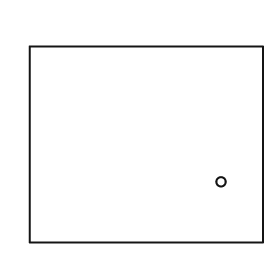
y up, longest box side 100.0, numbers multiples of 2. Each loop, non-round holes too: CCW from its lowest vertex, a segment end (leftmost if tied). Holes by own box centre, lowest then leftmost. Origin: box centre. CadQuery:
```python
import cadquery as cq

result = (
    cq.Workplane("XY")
    .moveTo(-50.0, -42.0)
    .lineTo(50.0, -42.0)
    .lineTo(50.0, 42.0)
    .lineTo(-50.0, 42.0)
    .close()
    .moveTo(32.0, -16.0)
    .circle(2.0)
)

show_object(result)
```